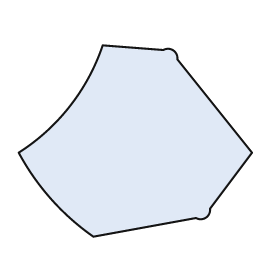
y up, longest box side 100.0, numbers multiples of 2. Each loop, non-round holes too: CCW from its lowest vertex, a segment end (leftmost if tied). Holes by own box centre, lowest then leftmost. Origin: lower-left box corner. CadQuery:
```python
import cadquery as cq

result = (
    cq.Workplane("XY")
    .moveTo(32.0, 0.0)
    .lineTo(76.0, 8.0)
    .threePointArc((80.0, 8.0), (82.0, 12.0))
    .lineTo(100.0, 36.0)
    .lineTo(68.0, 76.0)
    .threePointArc((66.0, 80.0), (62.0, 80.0))
    .lineTo(36.0, 82.0)
    .threePointArc((22.0, 56.0), (0.0, 36.0))
    .threePointArc((14.0, 16.0), (32.0, 0.0))
    .close()
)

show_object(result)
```